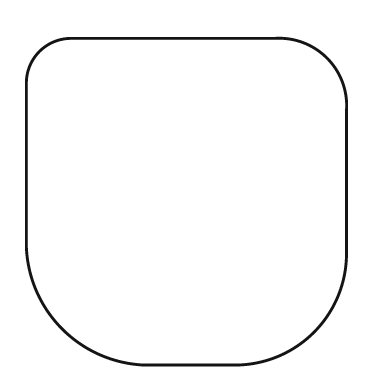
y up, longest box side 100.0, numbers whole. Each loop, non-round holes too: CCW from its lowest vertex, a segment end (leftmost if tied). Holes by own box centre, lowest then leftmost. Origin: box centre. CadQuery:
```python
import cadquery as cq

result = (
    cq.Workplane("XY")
    .moveTo(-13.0, -50.0)
    .lineTo(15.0, -50.0)
    .threePointArc((39.0, -40.0), (49.0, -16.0))
    .lineTo(49.0, 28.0)
    .threePointArc((43.0, 44.0), (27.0, 50.0))
    .lineTo(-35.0, 50.0)
    .threePointArc((-45.0, 46.0), (-49.0, 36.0))
    .lineTo(-49.0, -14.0)
    .threePointArc((-38.0, -39.0), (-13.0, -50.0))
    .close()
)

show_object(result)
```